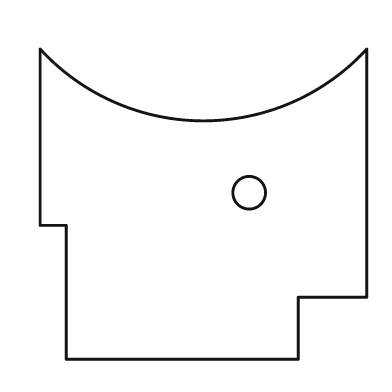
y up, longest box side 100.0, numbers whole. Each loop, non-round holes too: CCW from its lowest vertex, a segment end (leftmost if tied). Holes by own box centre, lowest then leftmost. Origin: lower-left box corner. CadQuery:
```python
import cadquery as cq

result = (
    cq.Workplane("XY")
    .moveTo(8.0, 0.0)
    .lineTo(79.0, 0.0)
    .lineTo(79.0, 19.0)
    .lineTo(100.0, 19.0)
    .lineTo(100.0, 95.0)
    .threePointArc((50.0, 73.0), (0.0, 95.0))
    .lineTo(0.0, 41.0)
    .lineTo(8.0, 41.0)
    .close()
    .moveTo(64.0, 51.0)
    .circle(5.0)
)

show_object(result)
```